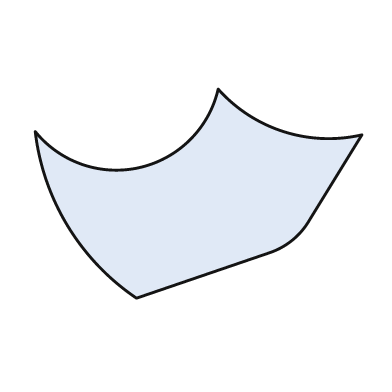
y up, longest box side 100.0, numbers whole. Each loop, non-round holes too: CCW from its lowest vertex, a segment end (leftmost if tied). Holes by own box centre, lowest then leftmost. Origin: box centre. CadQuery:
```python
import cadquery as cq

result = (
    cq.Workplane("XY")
    .moveTo(-19.0, -32.0)
    .lineTo(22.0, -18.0)
    .threePointArc((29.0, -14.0), (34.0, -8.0))
    .lineTo(50.0, 18.0)
    .threePointArc((26.0, 19.0), (6.0, 32.0))
    .threePointArc((-18.0, 8.0), (-50.0, 19.0))
    .threePointArc((-40.0, -10.0), (-19.0, -32.0))
    .close()
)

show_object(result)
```